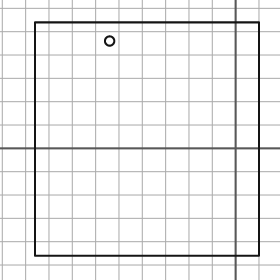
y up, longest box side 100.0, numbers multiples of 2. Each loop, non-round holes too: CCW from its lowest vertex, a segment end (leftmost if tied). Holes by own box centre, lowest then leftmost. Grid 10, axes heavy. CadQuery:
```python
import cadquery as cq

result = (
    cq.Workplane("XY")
    .moveTo(-86.0, -46.0)
    .lineTo(10.0, -46.0)
    .lineTo(10.0, 54.0)
    .lineTo(-86.0, 54.0)
    .close()
    .moveTo(-54.0, 46.0)
    .circle(2.0)
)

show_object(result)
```